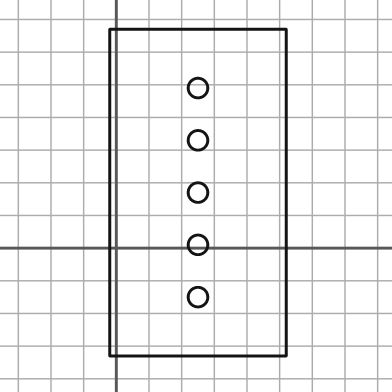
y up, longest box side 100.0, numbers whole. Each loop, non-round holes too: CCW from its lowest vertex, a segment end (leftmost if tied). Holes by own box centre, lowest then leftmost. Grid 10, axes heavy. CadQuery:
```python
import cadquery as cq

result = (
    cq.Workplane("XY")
    .moveTo(-2.0, -33.0)
    .lineTo(52.0, -33.0)
    .lineTo(52.0, 67.0)
    .lineTo(-2.0, 67.0)
    .close()
    .moveTo(25.0, -15.0)
    .circle(3.0)
    .moveTo(25.0, 1.0)
    .circle(3.0)
    .moveTo(25.0, 17.0)
    .circle(3.0)
    .moveTo(25.0, 33.0)
    .circle(3.0)
    .moveTo(25.0, 49.0)
    .circle(3.0)
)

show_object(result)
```